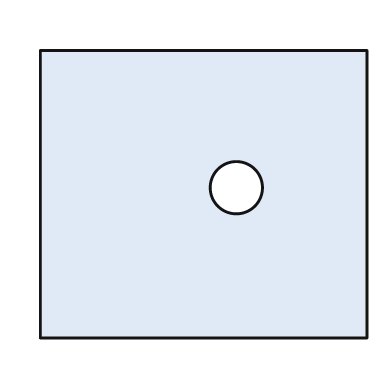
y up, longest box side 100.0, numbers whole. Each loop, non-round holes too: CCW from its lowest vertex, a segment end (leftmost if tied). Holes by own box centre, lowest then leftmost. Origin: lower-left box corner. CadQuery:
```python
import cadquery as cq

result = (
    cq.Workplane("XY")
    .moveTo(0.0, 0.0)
    .lineTo(100.0, 0.0)
    .lineTo(100.0, 88.0)
    .lineTo(0.0, 88.0)
    .close()
    .moveTo(60.0, 46.0)
    .circle(8.0)
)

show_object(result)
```